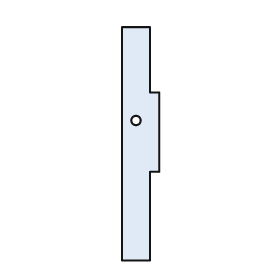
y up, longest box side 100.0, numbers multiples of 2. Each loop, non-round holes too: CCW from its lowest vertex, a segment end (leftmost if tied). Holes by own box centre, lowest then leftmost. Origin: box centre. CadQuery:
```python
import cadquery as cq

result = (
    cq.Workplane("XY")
    .moveTo(-8.0, -50.0)
    .lineTo(4.0, -50.0)
    .lineTo(4.0, -12.0)
    .lineTo(8.0, -12.0)
    .lineTo(8.0, 22.0)
    .lineTo(4.0, 22.0)
    .lineTo(4.0, 50.0)
    .lineTo(-8.0, 50.0)
    .close()
    .moveTo(-2.0, 10.0)
    .circle(2.0)
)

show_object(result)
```